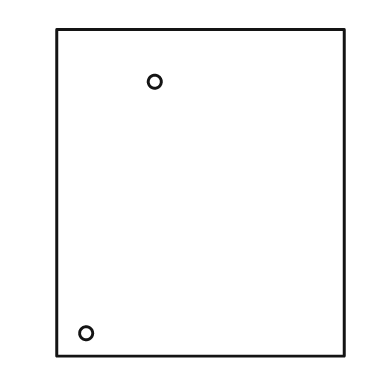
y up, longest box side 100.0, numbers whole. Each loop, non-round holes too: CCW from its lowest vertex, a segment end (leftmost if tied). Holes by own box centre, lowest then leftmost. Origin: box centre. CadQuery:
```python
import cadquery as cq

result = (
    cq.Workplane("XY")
    .moveTo(-44.0, -50.0)
    .lineTo(44.0, -50.0)
    .lineTo(44.0, 50.0)
    .lineTo(-44.0, 50.0)
    .close()
    .moveTo(-35.0, -43.0)
    .circle(2.0)
    .moveTo(-14.0, 34.0)
    .circle(2.0)
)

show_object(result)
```